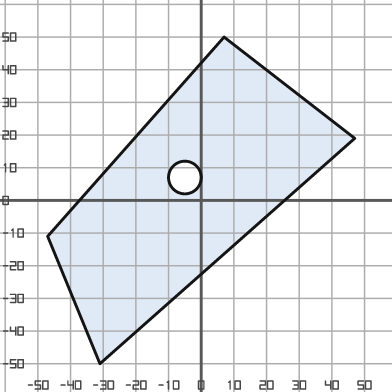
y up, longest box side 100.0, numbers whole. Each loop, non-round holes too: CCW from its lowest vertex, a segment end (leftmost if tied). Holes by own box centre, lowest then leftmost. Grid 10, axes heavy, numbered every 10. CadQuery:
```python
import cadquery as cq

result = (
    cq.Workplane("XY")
    .moveTo(-31.0, -50.0)
    .lineTo(47.0, 19.0)
    .lineTo(7.0, 50.0)
    .lineTo(-47.0, -11.0)
    .close()
    .moveTo(-5.0, 7.0)
    .circle(5.0)
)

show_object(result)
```